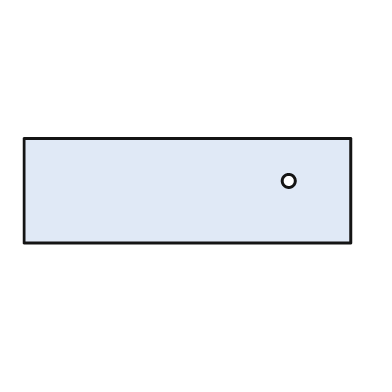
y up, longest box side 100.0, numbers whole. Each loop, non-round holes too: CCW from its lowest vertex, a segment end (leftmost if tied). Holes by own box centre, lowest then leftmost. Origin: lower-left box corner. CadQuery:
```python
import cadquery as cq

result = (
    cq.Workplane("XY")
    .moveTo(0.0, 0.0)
    .lineTo(100.0, 0.0)
    .lineTo(100.0, 32.0)
    .lineTo(0.0, 32.0)
    .close()
    .moveTo(81.0, 19.0)
    .circle(2.0)
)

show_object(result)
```